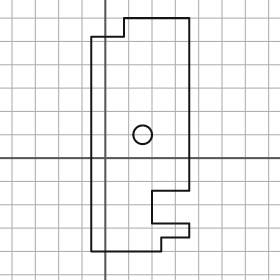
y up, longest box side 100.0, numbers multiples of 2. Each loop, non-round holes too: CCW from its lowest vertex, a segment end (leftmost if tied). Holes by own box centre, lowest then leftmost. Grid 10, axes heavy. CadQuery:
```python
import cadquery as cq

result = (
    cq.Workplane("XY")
    .moveTo(-6.0, -40.0)
    .lineTo(24.0, -40.0)
    .lineTo(24.0, -34.0)
    .lineTo(36.0, -34.0)
    .lineTo(36.0, -28.0)
    .lineTo(20.0, -28.0)
    .lineTo(20.0, -14.0)
    .lineTo(36.0, -14.0)
    .lineTo(36.0, 60.0)
    .lineTo(8.0, 60.0)
    .lineTo(8.0, 52.0)
    .lineTo(-6.0, 52.0)
    .close()
    .moveTo(16.0, 10.0)
    .circle(4.0)
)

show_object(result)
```